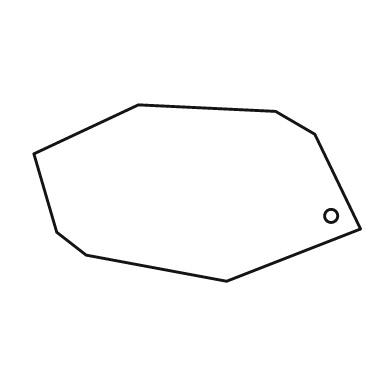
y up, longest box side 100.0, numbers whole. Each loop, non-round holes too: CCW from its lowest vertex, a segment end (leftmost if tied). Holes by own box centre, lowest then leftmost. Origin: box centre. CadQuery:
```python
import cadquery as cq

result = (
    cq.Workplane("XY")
    .moveTo(9.0, -27.0)
    .lineTo(50.0, -11.0)
    .lineTo(36.0, 18.0)
    .lineTo(24.0, 25.0)
    .lineTo(-18.0, 27.0)
    .lineTo(-50.0, 12.0)
    .lineTo(-43.0, -12.0)
    .lineTo(-34.0, -19.0)
    .close()
    .moveTo(41.0, -7.0)
    .circle(2.0)
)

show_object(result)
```